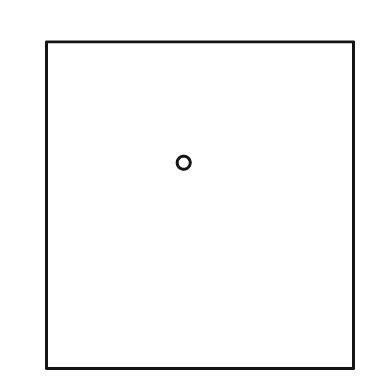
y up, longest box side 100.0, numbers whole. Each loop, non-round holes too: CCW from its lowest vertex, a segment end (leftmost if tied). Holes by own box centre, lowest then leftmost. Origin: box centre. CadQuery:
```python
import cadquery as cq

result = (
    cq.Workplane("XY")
    .moveTo(-47.0, -50.0)
    .lineTo(47.0, -50.0)
    .lineTo(47.0, 50.0)
    .lineTo(-47.0, 50.0)
    .close()
    .moveTo(-5.0, 13.0)
    .circle(2.0)
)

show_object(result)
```